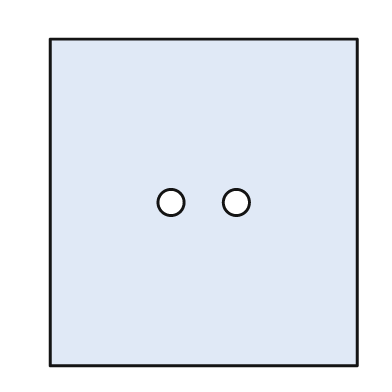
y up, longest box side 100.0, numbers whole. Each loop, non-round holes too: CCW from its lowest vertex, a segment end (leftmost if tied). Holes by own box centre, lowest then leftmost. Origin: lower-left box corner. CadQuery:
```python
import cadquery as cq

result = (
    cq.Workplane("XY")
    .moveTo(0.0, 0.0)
    .lineTo(94.0, 0.0)
    .lineTo(94.0, 100.0)
    .lineTo(0.0, 100.0)
    .close()
    .moveTo(37.0, 50.0)
    .circle(4.0)
    .moveTo(57.0, 50.0)
    .circle(4.0)
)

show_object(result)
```